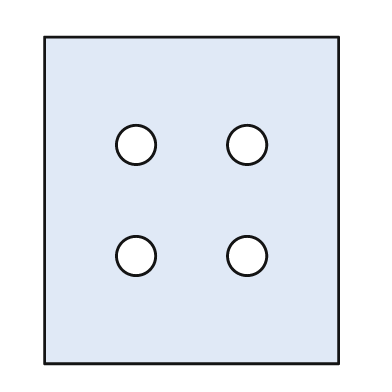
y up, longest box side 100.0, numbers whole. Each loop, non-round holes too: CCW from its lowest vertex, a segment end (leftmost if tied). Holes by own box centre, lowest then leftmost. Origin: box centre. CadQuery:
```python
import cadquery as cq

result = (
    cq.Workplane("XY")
    .moveTo(-45.0, -50.0)
    .lineTo(45.0, -50.0)
    .lineTo(45.0, 50.0)
    .lineTo(-45.0, 50.0)
    .close()
    .moveTo(-17.0, -17.0)
    .circle(6.0)
    .moveTo(17.0, -17.0)
    .circle(6.0)
    .moveTo(-17.0, 17.0)
    .circle(6.0)
    .moveTo(17.0, 17.0)
    .circle(6.0)
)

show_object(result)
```